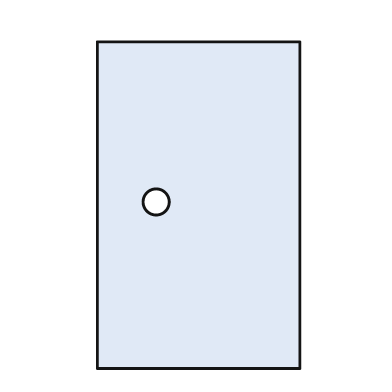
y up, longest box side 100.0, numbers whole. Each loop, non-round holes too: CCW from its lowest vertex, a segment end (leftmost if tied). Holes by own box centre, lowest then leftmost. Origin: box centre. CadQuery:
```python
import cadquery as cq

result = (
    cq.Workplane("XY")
    .moveTo(-31.0, -50.0)
    .lineTo(31.0, -50.0)
    .lineTo(31.0, 50.0)
    .lineTo(-31.0, 50.0)
    .close()
    .moveTo(-13.0, 1.0)
    .circle(4.0)
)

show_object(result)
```